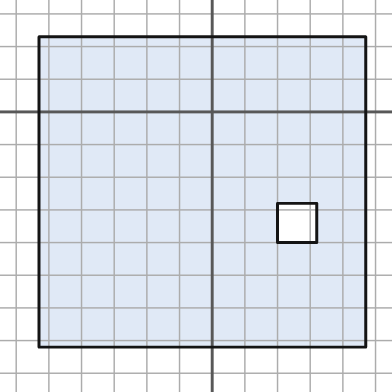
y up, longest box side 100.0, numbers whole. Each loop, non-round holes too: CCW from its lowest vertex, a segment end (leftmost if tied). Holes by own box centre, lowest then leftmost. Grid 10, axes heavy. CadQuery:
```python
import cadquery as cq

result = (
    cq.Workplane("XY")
    .moveTo(-53.0, -72.0)
    .lineTo(47.0, -72.0)
    .lineTo(47.0, 23.0)
    .lineTo(-53.0, 23.0)
    .close()
    .moveTo(20.0, -40.0)
    .lineTo(32.0, -40.0)
    .lineTo(32.0, -28.0)
    .lineTo(20.0, -28.0)
    .close()
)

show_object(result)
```